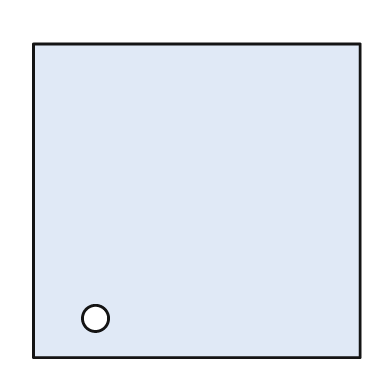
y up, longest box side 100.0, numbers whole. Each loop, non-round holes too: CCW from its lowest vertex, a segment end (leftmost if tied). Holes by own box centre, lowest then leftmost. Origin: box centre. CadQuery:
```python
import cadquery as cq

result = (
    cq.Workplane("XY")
    .moveTo(-50.0, -48.0)
    .lineTo(50.0, -48.0)
    .lineTo(50.0, 48.0)
    .lineTo(-50.0, 48.0)
    .close()
    .moveTo(-31.0, -36.0)
    .circle(4.0)
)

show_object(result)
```